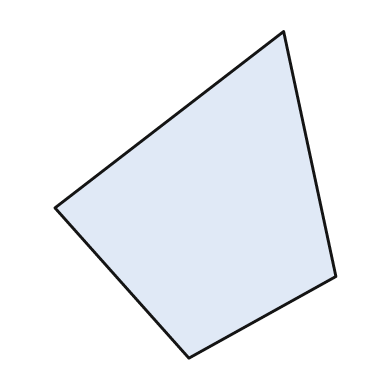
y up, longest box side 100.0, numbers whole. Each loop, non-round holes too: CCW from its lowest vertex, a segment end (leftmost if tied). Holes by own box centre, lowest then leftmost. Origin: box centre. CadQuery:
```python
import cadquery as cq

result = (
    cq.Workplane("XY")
    .moveTo(-2.0, -50.0)
    .lineTo(43.0, -25.0)
    .lineTo(27.0, 50.0)
    .lineTo(-43.0, -4.0)
    .close()
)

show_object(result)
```